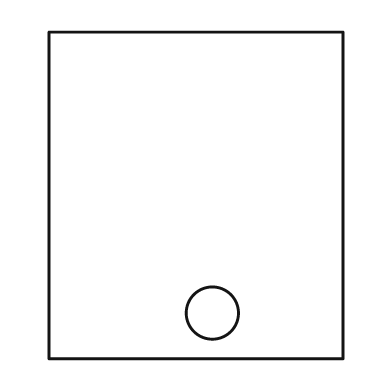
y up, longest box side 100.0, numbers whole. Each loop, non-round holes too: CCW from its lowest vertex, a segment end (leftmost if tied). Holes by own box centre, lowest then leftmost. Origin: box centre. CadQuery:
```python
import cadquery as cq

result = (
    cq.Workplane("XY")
    .moveTo(-45.0, -50.0)
    .lineTo(45.0, -50.0)
    .lineTo(45.0, 50.0)
    .lineTo(-45.0, 50.0)
    .close()
    .moveTo(5.0, -36.0)
    .circle(8.0)
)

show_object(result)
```